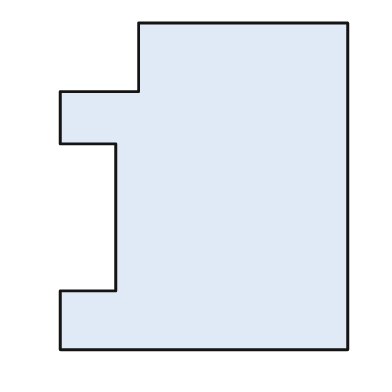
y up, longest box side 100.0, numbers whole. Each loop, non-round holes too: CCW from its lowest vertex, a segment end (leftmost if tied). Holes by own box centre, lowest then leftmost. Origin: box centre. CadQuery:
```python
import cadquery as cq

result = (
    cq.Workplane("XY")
    .moveTo(-44.0, -50.0)
    .lineTo(44.0, -50.0)
    .lineTo(44.0, 50.0)
    .lineTo(-20.0, 50.0)
    .lineTo(-20.0, 29.0)
    .lineTo(-44.0, 29.0)
    .lineTo(-44.0, 13.0)
    .lineTo(-27.0, 13.0)
    .lineTo(-27.0, -32.0)
    .lineTo(-44.0, -32.0)
    .close()
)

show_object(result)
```